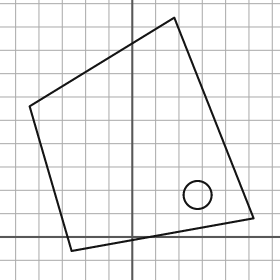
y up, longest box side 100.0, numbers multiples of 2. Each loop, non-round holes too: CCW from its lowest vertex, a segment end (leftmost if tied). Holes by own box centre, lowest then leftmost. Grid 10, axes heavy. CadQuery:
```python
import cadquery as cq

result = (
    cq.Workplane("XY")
    .moveTo(-26.0, -6.0)
    .lineTo(52.0, 8.0)
    .lineTo(18.0, 94.0)
    .lineTo(-44.0, 56.0)
    .close()
    .moveTo(28.0, 18.0)
    .circle(6.0)
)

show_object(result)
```